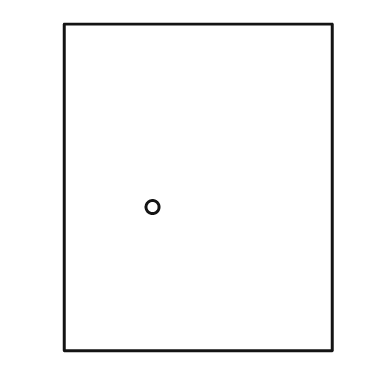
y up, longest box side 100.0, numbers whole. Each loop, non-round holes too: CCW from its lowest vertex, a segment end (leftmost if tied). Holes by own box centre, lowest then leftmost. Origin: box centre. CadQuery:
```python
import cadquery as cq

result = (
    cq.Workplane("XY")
    .moveTo(-41.0, -50.0)
    .lineTo(41.0, -50.0)
    .lineTo(41.0, 50.0)
    .lineTo(-41.0, 50.0)
    .close()
    .moveTo(-14.0, -6.0)
    .circle(2.0)
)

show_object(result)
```